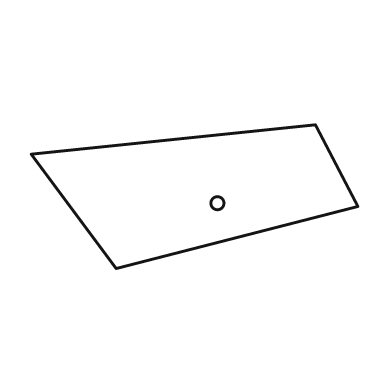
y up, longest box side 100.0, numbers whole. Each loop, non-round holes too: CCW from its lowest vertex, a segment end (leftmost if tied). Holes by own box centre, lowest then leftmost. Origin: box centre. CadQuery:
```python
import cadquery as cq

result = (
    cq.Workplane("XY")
    .moveTo(-24.0, -22.0)
    .lineTo(50.0, -3.0)
    .lineTo(37.0, 22.0)
    .lineTo(-50.0, 13.0)
    .close()
    .moveTo(7.0, -2.0)
    .circle(2.0)
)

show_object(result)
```